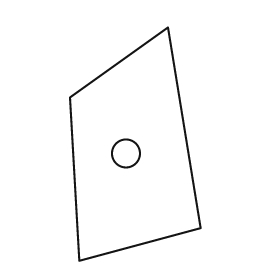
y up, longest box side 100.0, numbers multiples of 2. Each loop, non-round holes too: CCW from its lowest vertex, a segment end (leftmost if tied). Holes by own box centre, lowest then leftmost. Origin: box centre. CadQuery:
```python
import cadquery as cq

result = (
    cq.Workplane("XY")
    .moveTo(-24.0, -50.0)
    .lineTo(28.0, -36.0)
    .lineTo(14.0, 50.0)
    .lineTo(-28.0, 20.0)
    .close()
    .moveTo(-4.0, -4.0)
    .circle(6.0)
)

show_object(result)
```